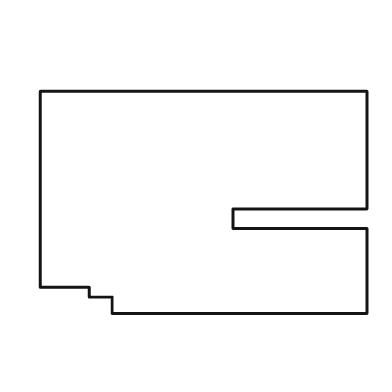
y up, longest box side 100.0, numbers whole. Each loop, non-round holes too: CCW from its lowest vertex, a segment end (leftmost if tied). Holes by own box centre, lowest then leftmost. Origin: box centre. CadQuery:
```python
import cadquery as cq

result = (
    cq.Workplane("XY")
    .moveTo(-28.0, -34.0)
    .lineTo(50.0, -34.0)
    .lineTo(50.0, -8.0)
    .lineTo(9.0, -8.0)
    .lineTo(9.0, -2.0)
    .lineTo(50.0, -2.0)
    .lineTo(50.0, 34.0)
    .lineTo(-50.0, 34.0)
    .lineTo(-50.0, -26.0)
    .lineTo(-35.0, -26.0)
    .lineTo(-35.0, -29.0)
    .lineTo(-28.0, -29.0)
    .close()
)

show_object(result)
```